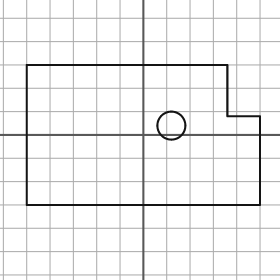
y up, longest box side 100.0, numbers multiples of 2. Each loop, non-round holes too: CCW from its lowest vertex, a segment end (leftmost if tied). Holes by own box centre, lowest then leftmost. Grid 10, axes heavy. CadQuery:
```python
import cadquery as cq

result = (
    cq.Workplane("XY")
    .moveTo(-50.0, -30.0)
    .lineTo(50.0, -30.0)
    .lineTo(50.0, 8.0)
    .lineTo(36.0, 8.0)
    .lineTo(36.0, 30.0)
    .lineTo(-50.0, 30.0)
    .close()
    .moveTo(12.0, 4.0)
    .circle(6.0)
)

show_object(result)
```